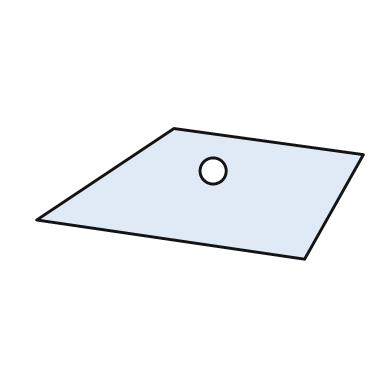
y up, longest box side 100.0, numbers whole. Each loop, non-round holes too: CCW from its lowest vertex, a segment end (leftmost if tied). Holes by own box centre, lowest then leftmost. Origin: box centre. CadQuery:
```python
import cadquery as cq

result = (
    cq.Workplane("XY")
    .moveTo(32.0, -20.0)
    .lineTo(50.0, 12.0)
    .lineTo(-8.0, 20.0)
    .lineTo(-50.0, -8.0)
    .close()
    .moveTo(4.0, 7.0)
    .circle(4.0)
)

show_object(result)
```